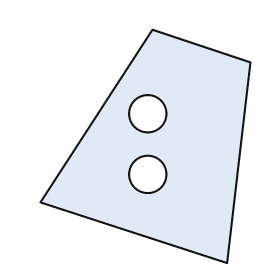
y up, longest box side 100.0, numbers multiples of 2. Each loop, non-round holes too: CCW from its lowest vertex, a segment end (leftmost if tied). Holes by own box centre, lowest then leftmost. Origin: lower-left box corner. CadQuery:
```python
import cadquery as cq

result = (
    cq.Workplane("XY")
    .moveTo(80.0, 0.0)
    .lineTo(90.0, 86.0)
    .lineTo(48.0, 100.0)
    .lineTo(0.0, 26.0)
    .close()
    .moveTo(46.0, 38.0)
    .circle(8.0)
    .moveTo(46.0, 64.0)
    .circle(8.0)
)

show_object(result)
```